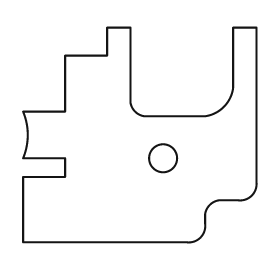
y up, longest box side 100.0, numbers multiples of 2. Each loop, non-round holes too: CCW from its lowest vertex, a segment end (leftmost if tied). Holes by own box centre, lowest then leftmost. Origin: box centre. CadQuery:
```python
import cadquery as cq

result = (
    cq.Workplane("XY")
    .moveTo(-50.0, -46.0)
    .lineTo(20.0, -46.0)
    .threePointArc((26.0, -44.0), (28.0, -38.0))
    .lineTo(28.0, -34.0)
    .threePointArc((30.0, -30.0), (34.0, -28.0))
    .lineTo(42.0, -28.0)
    .threePointArc((48.0, -26.0), (50.0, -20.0))
    .lineTo(50.0, 46.0)
    .lineTo(40.0, 46.0)
    .lineTo(40.0, 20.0)
    .threePointArc((36.0, 12.0), (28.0, 8.0))
    .lineTo(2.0, 8.0)
    .threePointArc((-2.0, 10.0), (-4.0, 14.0))
    .lineTo(-4.0, 46.0)
    .lineTo(-14.0, 46.0)
    .lineTo(-14.0, 34.0)
    .lineTo(-32.0, 34.0)
    .lineTo(-32.0, 10.0)
    .lineTo(-50.0, 10.0)
    .threePointArc((-48.0, 0.0), (-50.0, -10.0))
    .lineTo(-32.0, -10.0)
    .lineTo(-32.0, -18.0)
    .lineTo(-50.0, -18.0)
    .close()
    .moveTo(10.0, -10.0)
    .circle(6.0)
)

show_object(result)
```